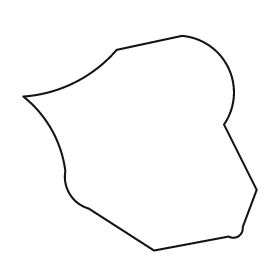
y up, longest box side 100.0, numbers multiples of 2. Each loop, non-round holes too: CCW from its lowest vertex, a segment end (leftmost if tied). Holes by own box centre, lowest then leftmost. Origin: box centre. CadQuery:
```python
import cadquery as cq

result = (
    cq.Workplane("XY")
    .moveTo(6.0, -46.0)
    .lineTo(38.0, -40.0)
    .threePointArc((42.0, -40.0), (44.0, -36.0))
    .lineTo(50.0, -20.0)
    .lineTo(36.0, 8.0)
    .threePointArc((38.0, 32.0), (18.0, 46.0))
    .lineTo(-10.0, 40.0)
    .threePointArc((-28.0, 26.0), (-50.0, 20.0))
    .threePointArc((-38.0, 6.0), (-32.0, -12.0))
    .threePointArc((-30.0, -22.0), (-22.0, -28.0))
    .close()
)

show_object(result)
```